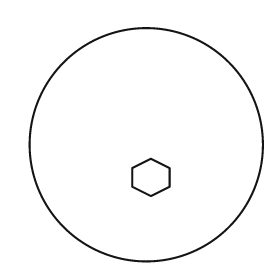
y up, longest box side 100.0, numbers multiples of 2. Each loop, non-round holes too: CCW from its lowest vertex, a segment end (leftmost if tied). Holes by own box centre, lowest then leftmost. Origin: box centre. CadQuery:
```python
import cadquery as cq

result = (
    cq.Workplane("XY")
    .moveTo(0.0, 0.0)
    .circle(50.0)
    .moveTo(2.0, -22.0)
    .lineTo(10.0, -18.0)
    .lineTo(10.0, -10.0)
    .lineTo(2.0, -6.0)
    .lineTo(-6.0, -10.0)
    .lineTo(-6.0, -18.0)
    .close()
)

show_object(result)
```